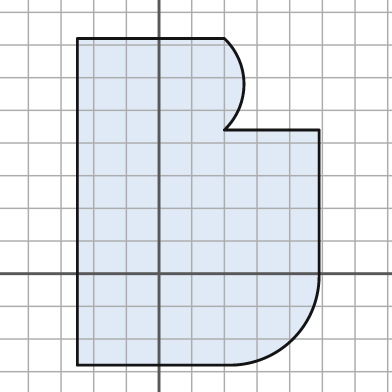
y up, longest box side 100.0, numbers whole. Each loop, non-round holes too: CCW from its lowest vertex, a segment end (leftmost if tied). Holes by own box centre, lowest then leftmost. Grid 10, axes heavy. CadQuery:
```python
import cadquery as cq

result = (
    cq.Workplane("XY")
    .moveTo(-25.0, -28.0)
    .lineTo(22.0, -28.0)
    .threePointArc((41.0, -20.0), (49.0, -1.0))
    .lineTo(49.0, 44.0)
    .lineTo(20.0, 44.0)
    .threePointArc((26.0, 58.0), (20.0, 72.0))
    .lineTo(-25.0, 72.0)
    .close()
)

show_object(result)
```